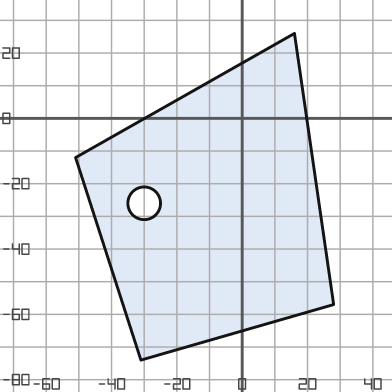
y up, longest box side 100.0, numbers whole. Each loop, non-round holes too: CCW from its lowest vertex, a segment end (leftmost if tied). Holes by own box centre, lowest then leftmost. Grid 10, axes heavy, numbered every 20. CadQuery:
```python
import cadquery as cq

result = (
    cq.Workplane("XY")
    .moveTo(-31.0, -74.0)
    .lineTo(28.0, -57.0)
    .lineTo(16.0, 26.0)
    .lineTo(-51.0, -12.0)
    .close()
    .moveTo(-30.0, -26.0)
    .circle(5.0)
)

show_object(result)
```